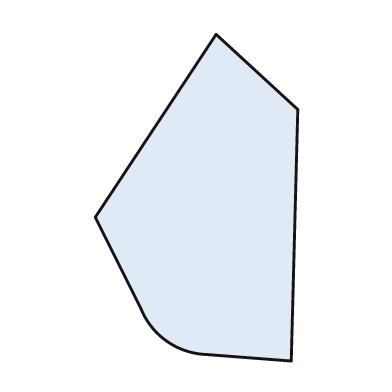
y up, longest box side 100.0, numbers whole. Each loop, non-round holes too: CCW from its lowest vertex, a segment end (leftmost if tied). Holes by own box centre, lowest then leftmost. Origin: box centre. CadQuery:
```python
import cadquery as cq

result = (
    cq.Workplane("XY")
    .moveTo(29.0, -50.0)
    .lineTo(31.0, 27.0)
    .lineTo(6.0, 50.0)
    .lineTo(-31.0, -6.0)
    .lineTo(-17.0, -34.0)
    .threePointArc((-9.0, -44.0), (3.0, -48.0))
    .close()
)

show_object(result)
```